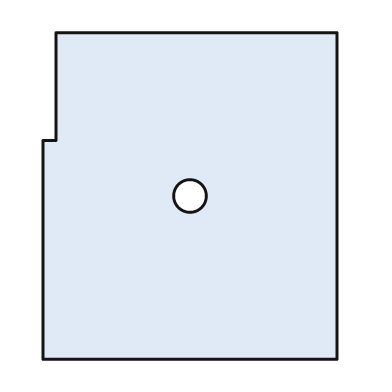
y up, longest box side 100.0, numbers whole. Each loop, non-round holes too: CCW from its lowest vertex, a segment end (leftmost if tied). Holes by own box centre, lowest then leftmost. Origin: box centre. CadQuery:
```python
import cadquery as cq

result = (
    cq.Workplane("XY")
    .moveTo(-45.0, -50.0)
    .lineTo(45.0, -50.0)
    .lineTo(45.0, 50.0)
    .lineTo(-41.0, 50.0)
    .lineTo(-41.0, 17.0)
    .lineTo(-45.0, 17.0)
    .close()
    .moveTo(0.0, 0.0)
    .circle(5.0)
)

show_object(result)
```